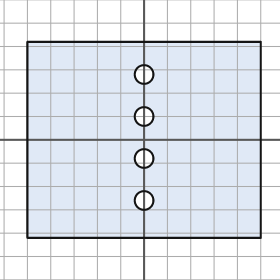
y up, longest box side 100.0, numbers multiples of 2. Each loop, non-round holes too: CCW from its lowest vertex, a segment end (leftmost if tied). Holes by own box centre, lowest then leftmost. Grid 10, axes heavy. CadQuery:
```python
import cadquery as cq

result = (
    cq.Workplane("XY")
    .moveTo(-50.0, -42.0)
    .lineTo(50.0, -42.0)
    .lineTo(50.0, 42.0)
    .lineTo(-50.0, 42.0)
    .close()
    .moveTo(0.0, -26.0)
    .circle(4.0)
    .moveTo(0.0, -8.0)
    .circle(4.0)
    .moveTo(0.0, 10.0)
    .circle(4.0)
    .moveTo(0.0, 28.0)
    .circle(4.0)
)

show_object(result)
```